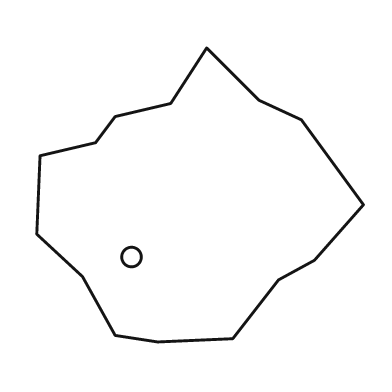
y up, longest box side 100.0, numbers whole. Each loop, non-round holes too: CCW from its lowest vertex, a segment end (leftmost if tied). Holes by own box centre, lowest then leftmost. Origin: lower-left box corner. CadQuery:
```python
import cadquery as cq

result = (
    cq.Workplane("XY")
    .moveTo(37.0, 0.0)
    .lineTo(60.0, 1.0)
    .lineTo(74.0, 19.0)
    .lineTo(85.0, 25.0)
    .lineTo(100.0, 42.0)
    .lineTo(81.0, 68.0)
    .lineTo(68.0, 74.0)
    .lineTo(52.0, 90.0)
    .lineTo(41.0, 73.0)
    .lineTo(24.0, 69.0)
    .lineTo(18.0, 61.0)
    .lineTo(1.0, 57.0)
    .lineTo(0.0, 33.0)
    .lineTo(14.0, 20.0)
    .lineTo(24.0, 2.0)
    .close()
    .moveTo(29.0, 26.0)
    .circle(3.0)
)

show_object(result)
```